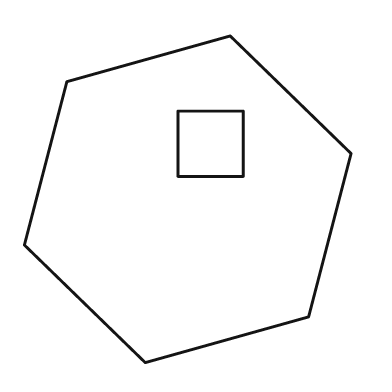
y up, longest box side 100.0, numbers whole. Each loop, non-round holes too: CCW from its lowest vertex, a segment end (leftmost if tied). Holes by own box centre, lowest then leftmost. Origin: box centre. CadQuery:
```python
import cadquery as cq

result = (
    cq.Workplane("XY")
    .moveTo(-13.0, -50.0)
    .lineTo(37.0, -36.0)
    .lineTo(50.0, 14.0)
    .lineTo(13.0, 50.0)
    .lineTo(-37.0, 36.0)
    .lineTo(-50.0, -14.0)
    .close()
    .moveTo(-3.0, 7.0)
    .lineTo(17.0, 7.0)
    .lineTo(17.0, 27.0)
    .lineTo(-3.0, 27.0)
    .close()
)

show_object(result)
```